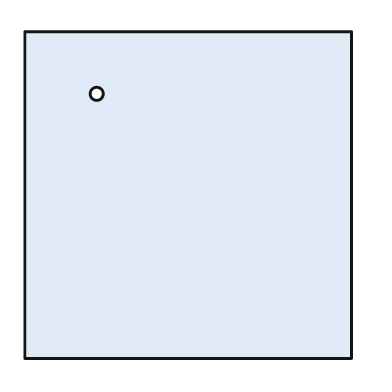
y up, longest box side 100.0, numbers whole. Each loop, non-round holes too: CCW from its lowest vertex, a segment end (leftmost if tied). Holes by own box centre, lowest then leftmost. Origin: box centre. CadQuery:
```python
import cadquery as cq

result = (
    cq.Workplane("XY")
    .moveTo(-50.0, -50.0)
    .lineTo(50.0, -50.0)
    .lineTo(50.0, 50.0)
    .lineTo(-50.0, 50.0)
    .close()
    .moveTo(-28.0, 31.0)
    .circle(2.0)
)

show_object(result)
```